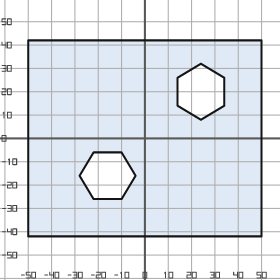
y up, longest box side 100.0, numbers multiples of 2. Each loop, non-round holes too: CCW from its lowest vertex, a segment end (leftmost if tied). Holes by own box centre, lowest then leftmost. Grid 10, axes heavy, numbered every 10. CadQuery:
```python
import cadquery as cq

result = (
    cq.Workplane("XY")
    .moveTo(-50.0, -42.0)
    .lineTo(50.0, -42.0)
    .lineTo(50.0, 42.0)
    .lineTo(-50.0, 42.0)
    .close()
    .moveTo(-22.0, -26.0)
    .lineTo(-10.0, -26.0)
    .lineTo(-4.0, -16.0)
    .lineTo(-10.0, -6.0)
    .lineTo(-22.0, -6.0)
    .lineTo(-28.0, -16.0)
    .close()
    .moveTo(24.0, 8.0)
    .lineTo(34.0, 14.0)
    .lineTo(34.0, 26.0)
    .lineTo(24.0, 32.0)
    .lineTo(14.0, 26.0)
    .lineTo(14.0, 14.0)
    .close()
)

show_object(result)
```